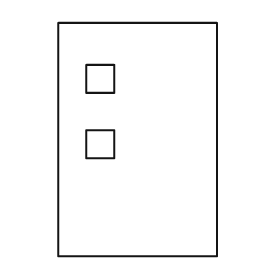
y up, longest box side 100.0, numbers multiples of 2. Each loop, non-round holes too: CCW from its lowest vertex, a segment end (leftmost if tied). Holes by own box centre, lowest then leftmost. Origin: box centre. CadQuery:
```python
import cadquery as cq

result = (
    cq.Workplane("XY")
    .moveTo(-34.0, -50.0)
    .lineTo(34.0, -50.0)
    .lineTo(34.0, 50.0)
    .lineTo(-34.0, 50.0)
    .close()
    .moveTo(-22.0, -8.0)
    .lineTo(-10.0, -8.0)
    .lineTo(-10.0, 4.0)
    .lineTo(-22.0, 4.0)
    .close()
    .moveTo(-22.0, 20.0)
    .lineTo(-10.0, 20.0)
    .lineTo(-10.0, 32.0)
    .lineTo(-22.0, 32.0)
    .close()
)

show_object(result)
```